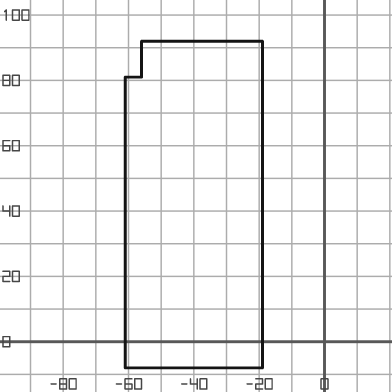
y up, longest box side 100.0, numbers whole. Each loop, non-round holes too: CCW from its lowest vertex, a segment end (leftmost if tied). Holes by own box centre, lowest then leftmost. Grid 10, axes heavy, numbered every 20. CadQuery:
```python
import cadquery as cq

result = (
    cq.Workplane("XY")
    .moveTo(-61.0, -8.0)
    .lineTo(-19.0, -8.0)
    .lineTo(-19.0, 92.0)
    .lineTo(-56.0, 92.0)
    .lineTo(-56.0, 81.0)
    .lineTo(-61.0, 81.0)
    .close()
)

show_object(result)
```